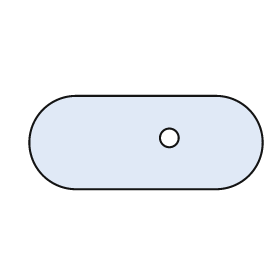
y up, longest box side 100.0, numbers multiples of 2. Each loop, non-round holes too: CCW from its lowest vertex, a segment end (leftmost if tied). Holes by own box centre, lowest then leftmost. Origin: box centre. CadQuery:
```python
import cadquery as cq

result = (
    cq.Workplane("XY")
    .moveTo(-30.0, -20.0)
    .lineTo(30.0, -20.0)
    .threePointArc((50.0, 0.0), (30.0, 20.0))
    .lineTo(-30.0, 20.0)
    .threePointArc((-50.0, 0.0), (-30.0, -20.0))
    .close()
    .moveTo(10.0, 2.0)
    .circle(4.0)
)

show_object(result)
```